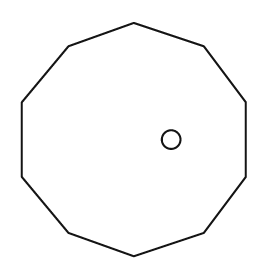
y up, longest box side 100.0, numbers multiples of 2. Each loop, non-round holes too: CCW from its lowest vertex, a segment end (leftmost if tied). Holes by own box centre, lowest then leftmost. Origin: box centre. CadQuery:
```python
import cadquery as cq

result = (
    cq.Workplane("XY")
    .moveTo(0.0, -50.0)
    .lineTo(30.0, -40.0)
    .lineTo(48.0, -16.0)
    .lineTo(48.0, 16.0)
    .lineTo(30.0, 40.0)
    .lineTo(0.0, 50.0)
    .lineTo(-28.0, 40.0)
    .lineTo(-48.0, 16.0)
    .lineTo(-48.0, -16.0)
    .lineTo(-28.0, -40.0)
    .close()
    .moveTo(16.0, 0.0)
    .circle(4.0)
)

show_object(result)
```